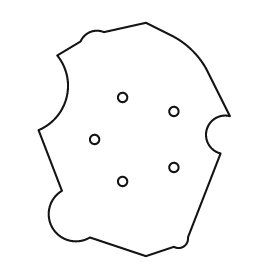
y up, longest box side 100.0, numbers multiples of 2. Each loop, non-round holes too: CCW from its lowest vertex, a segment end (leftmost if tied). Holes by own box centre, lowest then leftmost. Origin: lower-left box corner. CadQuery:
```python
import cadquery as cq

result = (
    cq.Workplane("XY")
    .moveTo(46.0, 0.0)
    .lineTo(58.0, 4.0)
    .threePointArc((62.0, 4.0), (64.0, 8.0))
    .lineTo(78.0, 44.0)
    .threePointArc((72.0, 54.0), (82.0, 60.0))
    .lineTo(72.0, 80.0)
    .threePointArc((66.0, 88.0), (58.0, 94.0))
    .lineTo(46.0, 100.0)
    .lineTo(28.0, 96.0)
    .threePointArc((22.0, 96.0), (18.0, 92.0))
    .lineTo(8.0, 86.0)
    .threePointArc((12.0, 68.0), (0.0, 54.0))
    .lineTo(10.0, 28.0)
    .threePointArc((6.0, 12.0), (22.0, 8.0))
    .close()
    .moveTo(36.0, 32.0)
    .circle(2.0)
    .moveTo(58.0, 38.0)
    .circle(2.0)
    .moveTo(24.0, 50.0)
    .circle(2.0)
    .moveTo(58.0, 62.0)
    .circle(2.0)
    .moveTo(36.0, 68.0)
    .circle(2.0)
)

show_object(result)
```